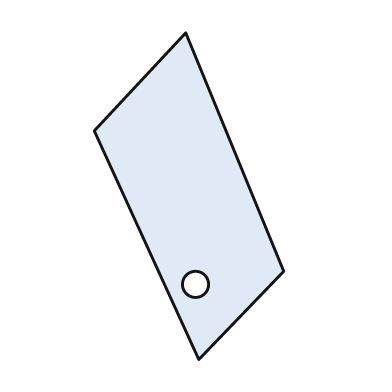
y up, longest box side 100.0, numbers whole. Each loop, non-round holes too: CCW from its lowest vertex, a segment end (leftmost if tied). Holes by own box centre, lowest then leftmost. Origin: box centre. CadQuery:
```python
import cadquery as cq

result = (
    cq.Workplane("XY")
    .moveTo(3.0, -50.0)
    .lineTo(29.0, -23.0)
    .lineTo(-1.0, 50.0)
    .lineTo(-29.0, 20.0)
    .close()
    .moveTo(2.0, -27.0)
    .circle(4.0)
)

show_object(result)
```